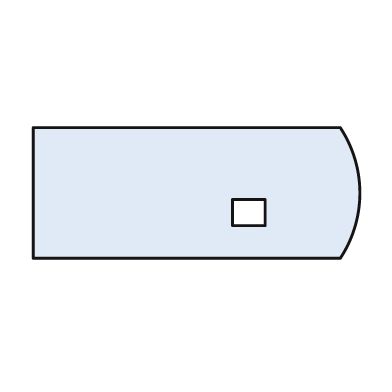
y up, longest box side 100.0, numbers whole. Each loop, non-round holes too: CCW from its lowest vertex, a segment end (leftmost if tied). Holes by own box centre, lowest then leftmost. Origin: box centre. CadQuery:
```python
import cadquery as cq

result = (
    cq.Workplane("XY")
    .moveTo(-50.0, -20.0)
    .lineTo(44.0, -20.0)
    .threePointArc((50.0, 0.0), (44.0, 20.0))
    .lineTo(-50.0, 20.0)
    .close()
    .moveTo(11.0, -10.0)
    .lineTo(21.0, -10.0)
    .lineTo(21.0, -2.0)
    .lineTo(11.0, -2.0)
    .close()
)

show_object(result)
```